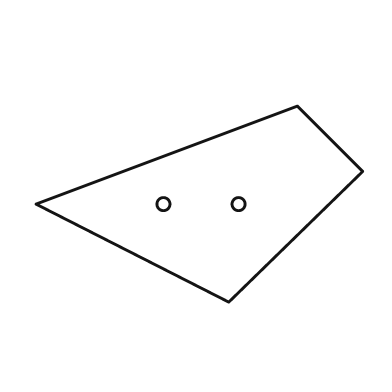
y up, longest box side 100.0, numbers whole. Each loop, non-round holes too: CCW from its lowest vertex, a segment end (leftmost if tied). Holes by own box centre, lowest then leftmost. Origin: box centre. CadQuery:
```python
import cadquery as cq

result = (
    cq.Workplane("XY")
    .moveTo(9.0, -30.0)
    .lineTo(50.0, 10.0)
    .lineTo(30.0, 30.0)
    .lineTo(-50.0, 0.0)
    .close()
    .moveTo(-11.0, 0.0)
    .circle(2.0)
    .moveTo(12.0, 0.0)
    .circle(2.0)
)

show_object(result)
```